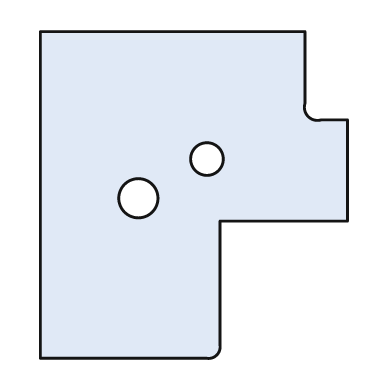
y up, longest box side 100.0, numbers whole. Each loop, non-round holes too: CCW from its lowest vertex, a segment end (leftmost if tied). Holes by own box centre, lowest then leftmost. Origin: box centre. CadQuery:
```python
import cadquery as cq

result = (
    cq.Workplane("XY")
    .moveTo(-47.0, -50.0)
    .lineTo(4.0, -50.0)
    .threePointArc((7.0, -49.0), (8.0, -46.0))
    .lineTo(8.0, -8.0)
    .lineTo(47.0, -8.0)
    .lineTo(47.0, 23.0)
    .lineTo(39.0, 23.0)
    .threePointArc((35.0, 24.0), (34.0, 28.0))
    .lineTo(34.0, 50.0)
    .lineTo(-47.0, 50.0)
    .close()
    .moveTo(-17.0, -1.0)
    .circle(6.0)
    .moveTo(4.0, 11.0)
    .circle(5.0)
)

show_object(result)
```